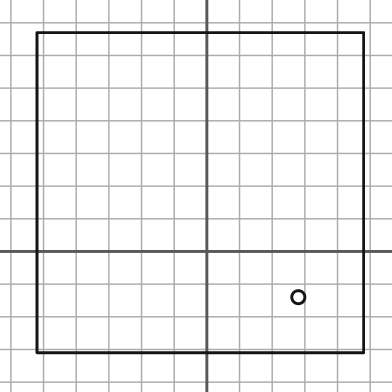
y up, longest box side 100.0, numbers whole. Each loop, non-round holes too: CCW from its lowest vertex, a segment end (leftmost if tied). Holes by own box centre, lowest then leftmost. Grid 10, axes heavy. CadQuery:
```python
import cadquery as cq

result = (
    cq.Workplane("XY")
    .moveTo(-52.0, -31.0)
    .lineTo(48.0, -31.0)
    .lineTo(48.0, 67.0)
    .lineTo(-52.0, 67.0)
    .close()
    .moveTo(28.0, -14.0)
    .circle(2.0)
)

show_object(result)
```